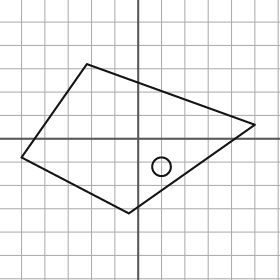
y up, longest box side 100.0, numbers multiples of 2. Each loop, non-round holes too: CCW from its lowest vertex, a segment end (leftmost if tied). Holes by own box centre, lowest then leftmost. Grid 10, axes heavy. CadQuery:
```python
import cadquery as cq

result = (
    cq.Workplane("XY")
    .moveTo(-4.0, -32.0)
    .lineTo(50.0, 6.0)
    .lineTo(-22.0, 32.0)
    .lineTo(-50.0, -8.0)
    .close()
    .moveTo(10.0, -12.0)
    .circle(4.0)
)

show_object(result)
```